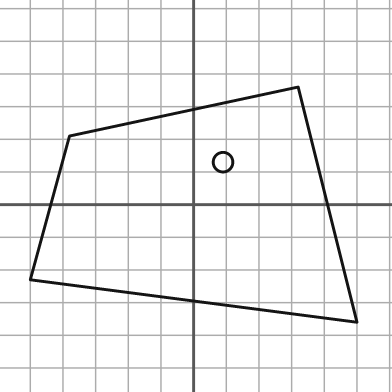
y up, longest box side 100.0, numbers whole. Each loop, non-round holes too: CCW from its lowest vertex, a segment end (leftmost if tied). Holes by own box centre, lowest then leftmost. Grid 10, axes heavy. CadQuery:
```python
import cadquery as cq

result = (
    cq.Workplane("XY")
    .moveTo(50.0, -36.0)
    .lineTo(32.0, 36.0)
    .lineTo(-38.0, 21.0)
    .lineTo(-50.0, -23.0)
    .close()
    .moveTo(9.0, 13.0)
    .circle(3.0)
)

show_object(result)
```